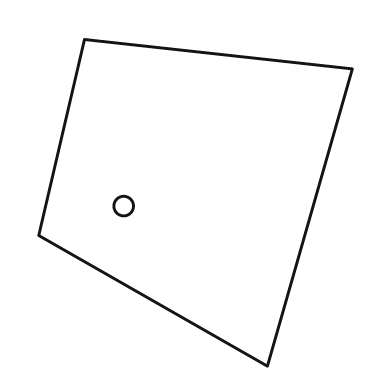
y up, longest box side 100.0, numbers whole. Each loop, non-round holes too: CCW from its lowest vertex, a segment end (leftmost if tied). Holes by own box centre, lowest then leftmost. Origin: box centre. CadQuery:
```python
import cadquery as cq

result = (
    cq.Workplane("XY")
    .moveTo(22.0, -50.0)
    .lineTo(48.0, 41.0)
    .lineTo(-34.0, 50.0)
    .lineTo(-48.0, -10.0)
    .close()
    .moveTo(-22.0, -1.0)
    .circle(3.0)
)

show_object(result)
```